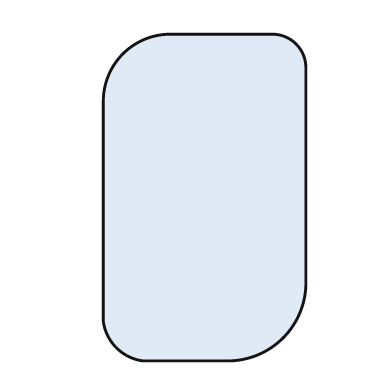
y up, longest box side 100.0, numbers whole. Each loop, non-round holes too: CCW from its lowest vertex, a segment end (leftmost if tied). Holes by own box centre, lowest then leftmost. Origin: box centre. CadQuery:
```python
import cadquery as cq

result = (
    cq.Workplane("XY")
    .moveTo(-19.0, -50.0)
    .lineTo(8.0, -50.0)
    .threePointArc((24.0, -43.0), (31.0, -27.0))
    .lineTo(31.0, 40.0)
    .threePointArc((28.0, 47.0), (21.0, 50.0))
    .lineTo(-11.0, 50.0)
    .threePointArc((-25.0, 44.0), (-31.0, 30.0))
    .lineTo(-31.0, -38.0)
    .threePointArc((-27.0, -46.0), (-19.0, -50.0))
    .close()
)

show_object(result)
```